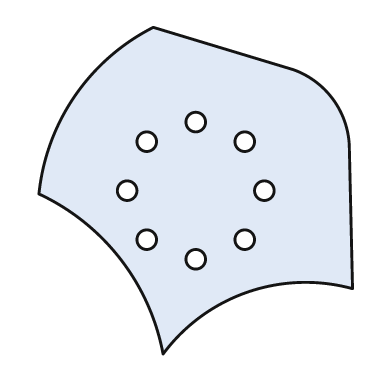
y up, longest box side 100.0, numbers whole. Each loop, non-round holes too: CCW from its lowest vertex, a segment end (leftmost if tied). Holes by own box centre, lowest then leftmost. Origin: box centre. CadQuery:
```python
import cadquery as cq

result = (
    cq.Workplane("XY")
    .moveTo(-10.0, -50.0)
    .threePointArc((16.0, -31.0), (48.0, -30.0))
    .lineTo(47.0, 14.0)
    .threePointArc((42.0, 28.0), (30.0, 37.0))
    .lineTo(-13.0, 50.0)
    .threePointArc((-37.0, 29.0), (-48.0, -1.0))
    .threePointArc((-23.0, -21.0), (-10.0, -50.0))
    .close()
    .moveTo(0.0, -21.0)
    .circle(3.0)
    .moveTo(-15.0, -15.0)
    .circle(3.0)
    .moveTo(15.0, -15.0)
    .circle(3.0)
    .moveTo(-21.0, 0.0)
    .circle(3.0)
    .moveTo(21.0, 0.0)
    .circle(3.0)
    .moveTo(-15.0, 15.0)
    .circle(3.0)
    .moveTo(15.0, 15.0)
    .circle(3.0)
    .moveTo(0.0, 21.0)
    .circle(3.0)
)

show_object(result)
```